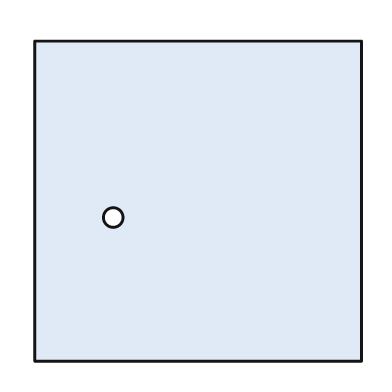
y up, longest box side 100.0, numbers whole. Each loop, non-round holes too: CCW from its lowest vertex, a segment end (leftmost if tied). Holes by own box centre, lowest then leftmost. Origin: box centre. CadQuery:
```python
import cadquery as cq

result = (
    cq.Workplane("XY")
    .moveTo(-50.0, -49.0)
    .lineTo(50.0, -49.0)
    .lineTo(50.0, 49.0)
    .lineTo(-50.0, 49.0)
    .close()
    .moveTo(-26.0, -5.0)
    .circle(3.0)
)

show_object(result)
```